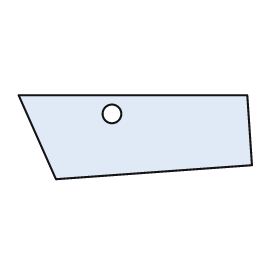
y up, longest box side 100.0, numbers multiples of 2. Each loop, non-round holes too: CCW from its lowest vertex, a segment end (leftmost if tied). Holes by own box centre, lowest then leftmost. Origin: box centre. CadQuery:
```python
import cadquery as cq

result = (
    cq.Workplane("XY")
    .moveTo(-34.0, -18.0)
    .lineTo(50.0, -12.0)
    .lineTo(48.0, 18.0)
    .lineTo(-50.0, 18.0)
    .close()
    .moveTo(-10.0, 10.0)
    .circle(4.0)
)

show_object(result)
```